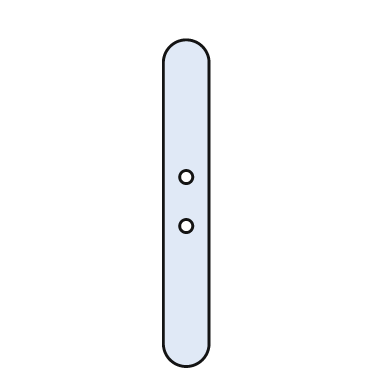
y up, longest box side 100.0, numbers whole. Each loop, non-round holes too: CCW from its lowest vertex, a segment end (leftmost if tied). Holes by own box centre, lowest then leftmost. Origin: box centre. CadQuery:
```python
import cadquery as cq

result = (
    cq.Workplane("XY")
    .moveTo(-7.0, -43.0)
    .threePointArc((0.0, -50.0), (7.0, -43.0))
    .lineTo(7.0, 43.0)
    .threePointArc((0.0, 50.0), (-7.0, 43.0))
    .close()
    .moveTo(0.0, -7.0)
    .circle(2.0)
    .moveTo(0.0, 8.0)
    .circle(2.0)
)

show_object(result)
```